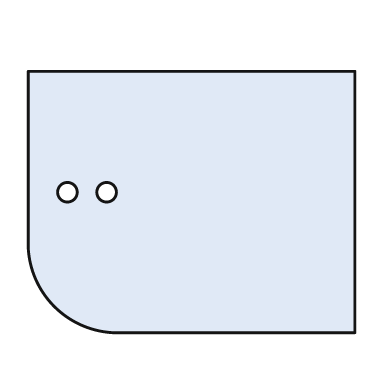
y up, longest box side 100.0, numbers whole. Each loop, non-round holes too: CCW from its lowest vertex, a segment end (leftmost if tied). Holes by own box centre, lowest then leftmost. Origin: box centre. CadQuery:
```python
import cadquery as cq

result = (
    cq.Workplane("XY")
    .moveTo(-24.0, -40.0)
    .lineTo(50.0, -40.0)
    .lineTo(50.0, 40.0)
    .lineTo(-50.0, 40.0)
    .lineTo(-50.0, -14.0)
    .threePointArc((-42.0, -32.0), (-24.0, -40.0))
    .close()
    .moveTo(-38.0, 3.0)
    .circle(3.0)
    .moveTo(-26.0, 3.0)
    .circle(3.0)
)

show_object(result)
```